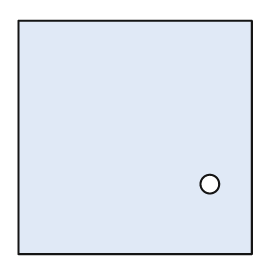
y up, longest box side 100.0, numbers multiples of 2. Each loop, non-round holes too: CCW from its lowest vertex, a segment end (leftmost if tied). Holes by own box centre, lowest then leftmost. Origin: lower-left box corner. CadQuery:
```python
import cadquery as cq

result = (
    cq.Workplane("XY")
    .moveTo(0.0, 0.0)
    .lineTo(100.0, 0.0)
    .lineTo(100.0, 100.0)
    .lineTo(0.0, 100.0)
    .close()
    .moveTo(82.0, 30.0)
    .circle(4.0)
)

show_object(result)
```